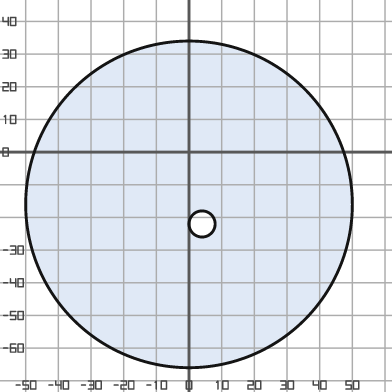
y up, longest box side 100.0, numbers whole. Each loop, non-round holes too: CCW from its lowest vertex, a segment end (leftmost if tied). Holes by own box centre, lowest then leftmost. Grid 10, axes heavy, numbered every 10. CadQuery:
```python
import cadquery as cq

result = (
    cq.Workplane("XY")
    .moveTo(0.0, -16.0)
    .circle(50.0)
    .moveTo(4.0, -22.0)
    .circle(4.0)
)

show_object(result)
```